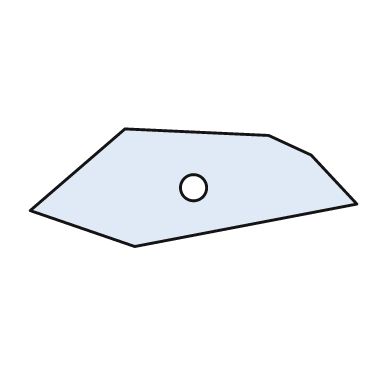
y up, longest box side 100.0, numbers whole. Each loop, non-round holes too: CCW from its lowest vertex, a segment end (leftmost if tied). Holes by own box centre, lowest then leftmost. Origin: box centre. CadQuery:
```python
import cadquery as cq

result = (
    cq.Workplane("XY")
    .moveTo(-18.0, -18.0)
    .lineTo(50.0, -5.0)
    .lineTo(36.0, 10.0)
    .lineTo(23.0, 16.0)
    .lineTo(-21.0, 18.0)
    .lineTo(-50.0, -7.0)
    .close()
    .moveTo(0.0, 0.0)
    .circle(4.0)
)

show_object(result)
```